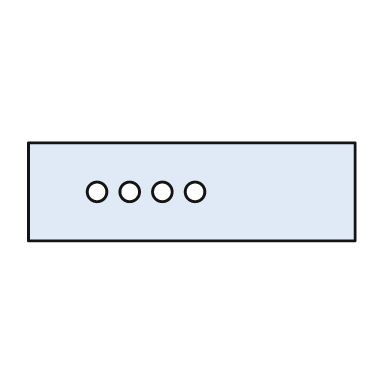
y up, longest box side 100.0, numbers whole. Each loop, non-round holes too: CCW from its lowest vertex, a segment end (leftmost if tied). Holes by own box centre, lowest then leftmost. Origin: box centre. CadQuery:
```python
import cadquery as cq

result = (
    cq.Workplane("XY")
    .moveTo(-50.0, -15.0)
    .lineTo(50.0, -15.0)
    .lineTo(50.0, 15.0)
    .lineTo(-50.0, 15.0)
    .close()
    .moveTo(-29.0, 0.0)
    .circle(3.0)
    .moveTo(-19.0, 0.0)
    .circle(3.0)
    .moveTo(-9.0, 0.0)
    .circle(3.0)
    .moveTo(1.0, 0.0)
    .circle(3.0)
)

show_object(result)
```